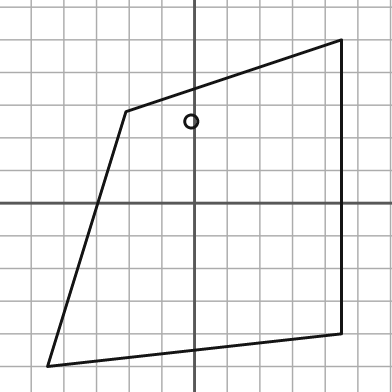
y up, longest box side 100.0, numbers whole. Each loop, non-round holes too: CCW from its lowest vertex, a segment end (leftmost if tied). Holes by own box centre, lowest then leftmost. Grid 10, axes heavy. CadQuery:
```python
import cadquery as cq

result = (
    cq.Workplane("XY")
    .moveTo(-45.0, -50.0)
    .lineTo(45.0, -40.0)
    .lineTo(45.0, 50.0)
    .lineTo(-21.0, 28.0)
    .close()
    .moveTo(-1.0, 25.0)
    .circle(2.0)
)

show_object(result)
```